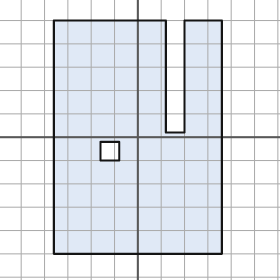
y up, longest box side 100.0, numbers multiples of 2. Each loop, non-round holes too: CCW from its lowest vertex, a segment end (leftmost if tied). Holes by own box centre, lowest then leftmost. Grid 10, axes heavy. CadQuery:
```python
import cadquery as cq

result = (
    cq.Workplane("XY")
    .moveTo(-36.0, -50.0)
    .lineTo(36.0, -50.0)
    .lineTo(36.0, 50.0)
    .lineTo(20.0, 50.0)
    .lineTo(20.0, 2.0)
    .lineTo(12.0, 2.0)
    .lineTo(12.0, 50.0)
    .lineTo(-36.0, 50.0)
    .close()
    .moveTo(-16.0, -10.0)
    .lineTo(-8.0, -10.0)
    .lineTo(-8.0, -2.0)
    .lineTo(-16.0, -2.0)
    .close()
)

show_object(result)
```